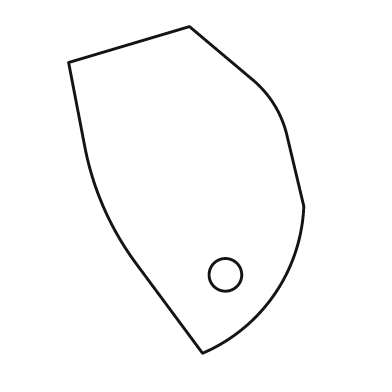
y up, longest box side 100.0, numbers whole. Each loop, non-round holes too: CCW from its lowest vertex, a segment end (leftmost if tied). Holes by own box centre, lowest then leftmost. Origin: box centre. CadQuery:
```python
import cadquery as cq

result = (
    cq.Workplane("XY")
    .moveTo(5.0, -50.0)
    .threePointArc((27.0, -32.0), (36.0, -5.0))
    .lineTo(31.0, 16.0)
    .threePointArc((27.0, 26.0), (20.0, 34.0))
    .lineTo(1.0, 50.0)
    .lineTo(-36.0, 39.0)
    .lineTo(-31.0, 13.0)
    .threePointArc((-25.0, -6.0), (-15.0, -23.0))
    .close()
    .moveTo(12.0, -26.0)
    .circle(5.0)
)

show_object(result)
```